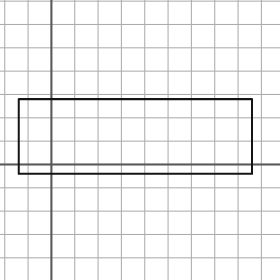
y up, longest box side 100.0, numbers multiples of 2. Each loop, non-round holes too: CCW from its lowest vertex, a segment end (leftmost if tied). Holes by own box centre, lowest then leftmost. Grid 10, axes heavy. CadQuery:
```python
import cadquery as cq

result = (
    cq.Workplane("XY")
    .moveTo(-14.0, -4.0)
    .lineTo(86.0, -4.0)
    .lineTo(86.0, 28.0)
    .lineTo(-14.0, 28.0)
    .close()
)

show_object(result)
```